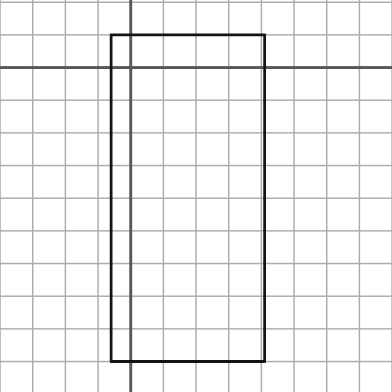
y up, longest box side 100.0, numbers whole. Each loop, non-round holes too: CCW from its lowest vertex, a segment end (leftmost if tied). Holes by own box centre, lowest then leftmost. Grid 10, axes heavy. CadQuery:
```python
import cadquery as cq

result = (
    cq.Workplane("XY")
    .moveTo(-6.0, -90.0)
    .lineTo(41.0, -90.0)
    .lineTo(41.0, 10.0)
    .lineTo(-6.0, 10.0)
    .close()
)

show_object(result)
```